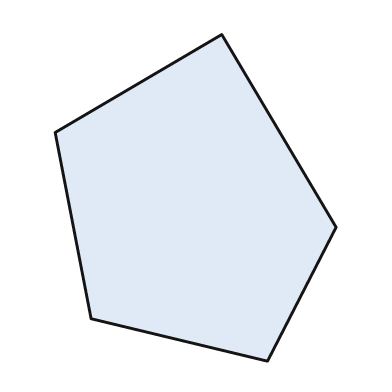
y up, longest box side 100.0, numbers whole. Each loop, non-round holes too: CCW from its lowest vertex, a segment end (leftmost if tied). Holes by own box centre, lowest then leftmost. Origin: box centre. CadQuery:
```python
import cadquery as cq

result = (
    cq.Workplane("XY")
    .moveTo(22.0, -50.0)
    .lineTo(43.0, -9.0)
    .lineTo(8.0, 50.0)
    .lineTo(-43.0, 20.0)
    .lineTo(-32.0, -37.0)
    .close()
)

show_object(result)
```